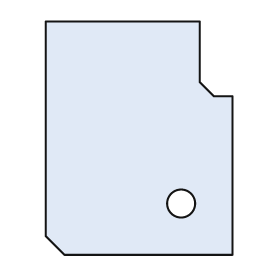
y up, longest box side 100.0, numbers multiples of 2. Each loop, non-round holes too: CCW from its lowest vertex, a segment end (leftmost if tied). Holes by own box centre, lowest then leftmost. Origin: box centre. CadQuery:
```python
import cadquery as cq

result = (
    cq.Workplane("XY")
    .moveTo(-32.0, -50.0)
    .lineTo(40.0, -50.0)
    .lineTo(40.0, 18.0)
    .lineTo(32.0, 18.0)
    .lineTo(26.0, 24.0)
    .lineTo(26.0, 50.0)
    .lineTo(-40.0, 50.0)
    .lineTo(-40.0, -42.0)
    .close()
    .moveTo(18.0, -28.0)
    .circle(6.0)
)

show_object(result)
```